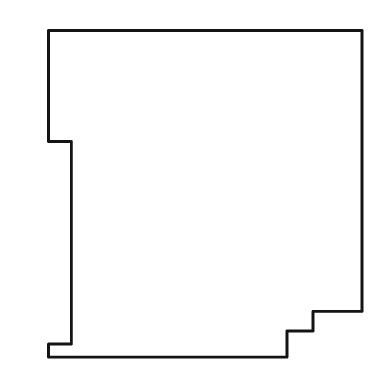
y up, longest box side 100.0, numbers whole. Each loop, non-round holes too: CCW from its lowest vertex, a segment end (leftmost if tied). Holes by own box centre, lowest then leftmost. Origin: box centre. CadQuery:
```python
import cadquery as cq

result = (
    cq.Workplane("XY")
    .moveTo(-48.0, -50.0)
    .lineTo(25.0, -50.0)
    .lineTo(25.0, -42.0)
    .lineTo(33.0, -42.0)
    .lineTo(33.0, -36.0)
    .lineTo(48.0, -36.0)
    .lineTo(48.0, 50.0)
    .lineTo(-48.0, 50.0)
    .lineTo(-48.0, 16.0)
    .lineTo(-41.0, 16.0)
    .lineTo(-41.0, -46.0)
    .lineTo(-48.0, -46.0)
    .close()
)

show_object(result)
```